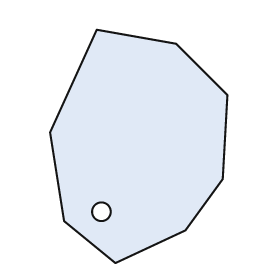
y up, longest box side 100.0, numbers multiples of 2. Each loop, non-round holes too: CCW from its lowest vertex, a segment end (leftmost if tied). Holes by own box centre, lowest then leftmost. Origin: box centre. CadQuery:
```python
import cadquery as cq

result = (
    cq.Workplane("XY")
    .moveTo(-10.0, -50.0)
    .lineTo(20.0, -36.0)
    .lineTo(36.0, -14.0)
    .lineTo(38.0, 22.0)
    .lineTo(16.0, 44.0)
    .lineTo(-18.0, 50.0)
    .lineTo(-38.0, 6.0)
    .lineTo(-32.0, -32.0)
    .close()
    .moveTo(-16.0, -28.0)
    .circle(4.0)
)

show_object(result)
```